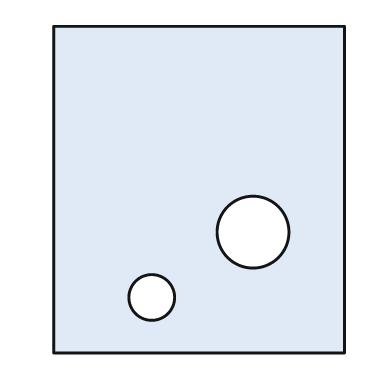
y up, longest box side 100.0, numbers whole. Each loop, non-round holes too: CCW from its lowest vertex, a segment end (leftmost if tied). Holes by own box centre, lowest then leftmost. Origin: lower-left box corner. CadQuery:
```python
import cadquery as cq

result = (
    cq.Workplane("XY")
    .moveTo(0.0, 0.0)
    .lineTo(89.0, 0.0)
    .lineTo(89.0, 100.0)
    .lineTo(0.0, 100.0)
    .close()
    .moveTo(30.0, 17.0)
    .circle(7.0)
    .moveTo(61.0, 37.0)
    .circle(11.0)
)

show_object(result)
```